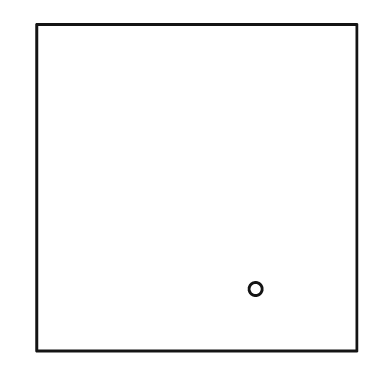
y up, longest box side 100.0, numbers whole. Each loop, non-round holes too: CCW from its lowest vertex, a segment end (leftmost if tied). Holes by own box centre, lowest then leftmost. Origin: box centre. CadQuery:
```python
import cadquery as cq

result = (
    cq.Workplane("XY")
    .moveTo(-49.0, -50.0)
    .lineTo(49.0, -50.0)
    .lineTo(49.0, 50.0)
    .lineTo(-49.0, 50.0)
    .close()
    .moveTo(18.0, -31.0)
    .circle(2.0)
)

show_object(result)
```